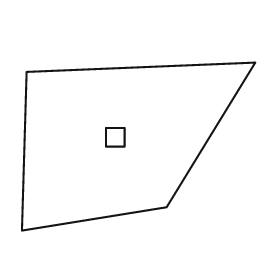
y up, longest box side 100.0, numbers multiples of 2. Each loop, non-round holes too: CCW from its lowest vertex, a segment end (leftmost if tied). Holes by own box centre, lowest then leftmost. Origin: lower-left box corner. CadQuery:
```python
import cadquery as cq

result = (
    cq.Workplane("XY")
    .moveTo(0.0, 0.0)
    .lineTo(62.0, 10.0)
    .lineTo(100.0, 72.0)
    .lineTo(2.0, 68.0)
    .close()
    .moveTo(36.0, 36.0)
    .lineTo(44.0, 36.0)
    .lineTo(44.0, 44.0)
    .lineTo(36.0, 44.0)
    .close()
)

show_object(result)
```